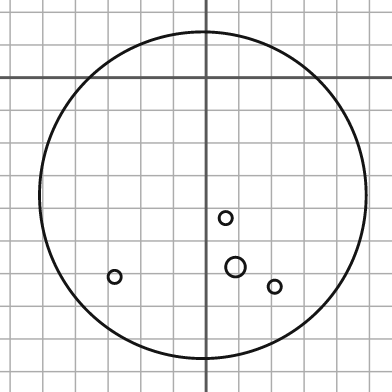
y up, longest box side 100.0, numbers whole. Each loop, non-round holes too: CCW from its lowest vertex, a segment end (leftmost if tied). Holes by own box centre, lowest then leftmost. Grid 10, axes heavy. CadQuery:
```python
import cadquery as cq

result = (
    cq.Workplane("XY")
    .moveTo(-1.0, -36.0)
    .circle(50.0)
    .moveTo(21.0, -64.0)
    .circle(2.0)
    .moveTo(-28.0, -61.0)
    .circle(2.0)
    .moveTo(9.0, -58.0)
    .circle(3.0)
    .moveTo(6.0, -43.0)
    .circle(2.0)
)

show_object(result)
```